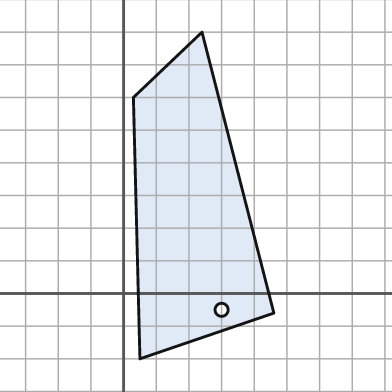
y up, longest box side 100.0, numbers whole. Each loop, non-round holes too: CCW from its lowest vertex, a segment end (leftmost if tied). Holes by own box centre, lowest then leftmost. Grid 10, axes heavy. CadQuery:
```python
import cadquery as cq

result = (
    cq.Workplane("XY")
    .moveTo(5.0, -20.0)
    .lineTo(46.0, -6.0)
    .lineTo(24.0, 80.0)
    .lineTo(3.0, 60.0)
    .close()
    .moveTo(30.0, -5.0)
    .circle(2.0)
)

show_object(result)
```